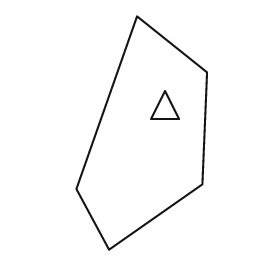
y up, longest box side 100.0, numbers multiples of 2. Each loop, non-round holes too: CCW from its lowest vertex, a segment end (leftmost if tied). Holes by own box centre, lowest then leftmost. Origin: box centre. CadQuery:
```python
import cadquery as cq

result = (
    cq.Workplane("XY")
    .moveTo(-14.0, -50.0)
    .lineTo(26.0, -22.0)
    .lineTo(28.0, 26.0)
    .lineTo(-2.0, 50.0)
    .lineTo(-28.0, -24.0)
    .close()
    .moveTo(4.0, 6.0)
    .lineTo(16.0, 6.0)
    .lineTo(10.0, 18.0)
    .close()
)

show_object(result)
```